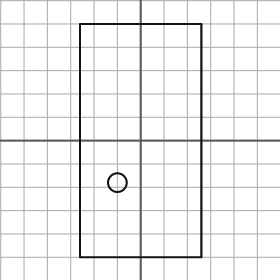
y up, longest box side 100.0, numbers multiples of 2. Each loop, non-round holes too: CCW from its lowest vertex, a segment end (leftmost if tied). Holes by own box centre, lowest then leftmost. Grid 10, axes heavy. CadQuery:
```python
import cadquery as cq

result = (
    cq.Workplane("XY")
    .moveTo(-26.0, -50.0)
    .lineTo(26.0, -50.0)
    .lineTo(26.0, 50.0)
    .lineTo(-26.0, 50.0)
    .close()
    .moveTo(-10.0, -18.0)
    .circle(4.0)
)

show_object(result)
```